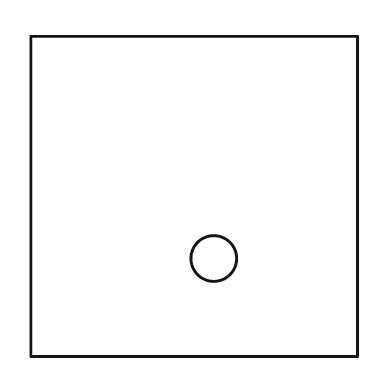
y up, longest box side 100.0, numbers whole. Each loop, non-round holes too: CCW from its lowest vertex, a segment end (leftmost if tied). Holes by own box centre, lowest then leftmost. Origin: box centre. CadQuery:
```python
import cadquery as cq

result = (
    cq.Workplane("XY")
    .moveTo(-50.0, -49.0)
    .lineTo(50.0, -49.0)
    .lineTo(50.0, 49.0)
    .lineTo(-50.0, 49.0)
    .close()
    .moveTo(6.0, -19.0)
    .circle(7.0)
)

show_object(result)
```